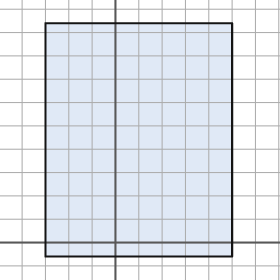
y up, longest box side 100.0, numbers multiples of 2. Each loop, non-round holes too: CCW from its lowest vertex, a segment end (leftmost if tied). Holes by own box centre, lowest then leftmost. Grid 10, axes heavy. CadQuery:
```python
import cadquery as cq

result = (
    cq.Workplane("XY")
    .moveTo(-30.0, -6.0)
    .lineTo(50.0, -6.0)
    .lineTo(50.0, 94.0)
    .lineTo(-30.0, 94.0)
    .close()
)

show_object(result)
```